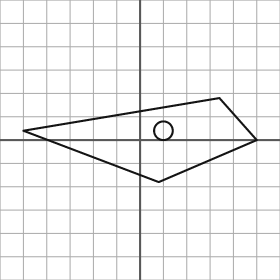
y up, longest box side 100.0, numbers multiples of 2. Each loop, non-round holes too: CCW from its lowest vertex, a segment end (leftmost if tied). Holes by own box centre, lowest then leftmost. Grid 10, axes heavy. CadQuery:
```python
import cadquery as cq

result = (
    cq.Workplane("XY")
    .moveTo(8.0, -18.0)
    .lineTo(50.0, 0.0)
    .lineTo(34.0, 18.0)
    .lineTo(-50.0, 4.0)
    .close()
    .moveTo(10.0, 4.0)
    .circle(4.0)
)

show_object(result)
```